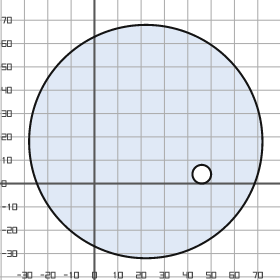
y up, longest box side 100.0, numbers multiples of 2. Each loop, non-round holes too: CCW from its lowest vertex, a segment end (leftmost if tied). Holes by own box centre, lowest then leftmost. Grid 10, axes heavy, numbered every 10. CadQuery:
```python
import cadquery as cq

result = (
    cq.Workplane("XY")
    .moveTo(22.0, 18.0)
    .circle(50.0)
    .moveTo(46.0, 4.0)
    .circle(4.0)
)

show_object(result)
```